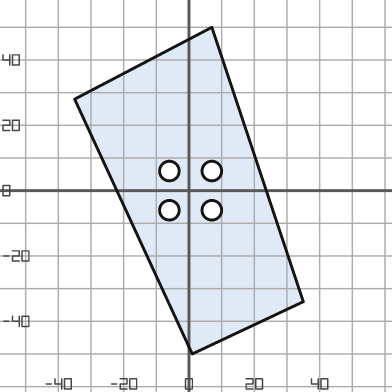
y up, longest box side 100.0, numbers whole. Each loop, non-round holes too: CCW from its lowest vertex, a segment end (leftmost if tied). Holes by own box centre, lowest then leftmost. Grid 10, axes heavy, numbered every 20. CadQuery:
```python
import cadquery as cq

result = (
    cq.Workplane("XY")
    .moveTo(1.0, -50.0)
    .lineTo(35.0, -34.0)
    .lineTo(7.0, 50.0)
    .lineTo(-35.0, 28.0)
    .close()
    .moveTo(-6.0, -6.0)
    .circle(3.0)
    .moveTo(7.0, -6.0)
    .circle(3.0)
    .moveTo(-6.0, 6.0)
    .circle(3.0)
    .moveTo(7.0, 6.0)
    .circle(3.0)
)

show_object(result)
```